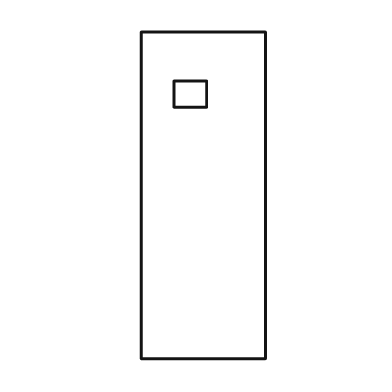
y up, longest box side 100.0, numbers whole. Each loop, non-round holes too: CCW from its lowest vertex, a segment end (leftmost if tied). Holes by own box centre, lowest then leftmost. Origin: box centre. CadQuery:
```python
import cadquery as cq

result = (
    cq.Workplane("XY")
    .moveTo(-19.0, -50.0)
    .lineTo(19.0, -50.0)
    .lineTo(19.0, 50.0)
    .lineTo(-19.0, 50.0)
    .close()
    .moveTo(-9.0, 27.0)
    .lineTo(1.0, 27.0)
    .lineTo(1.0, 35.0)
    .lineTo(-9.0, 35.0)
    .close()
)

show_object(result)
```